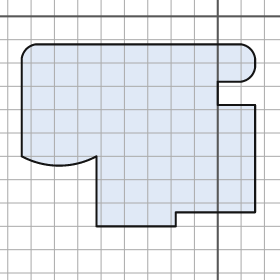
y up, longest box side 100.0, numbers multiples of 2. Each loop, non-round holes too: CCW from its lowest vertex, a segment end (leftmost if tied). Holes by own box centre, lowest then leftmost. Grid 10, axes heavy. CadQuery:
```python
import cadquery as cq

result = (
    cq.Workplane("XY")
    .moveTo(-52.0, -90.0)
    .lineTo(-18.0, -90.0)
    .lineTo(-18.0, -84.0)
    .lineTo(16.0, -84.0)
    .lineTo(16.0, -38.0)
    .lineTo(0.0, -38.0)
    .lineTo(0.0, -28.0)
    .lineTo(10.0, -28.0)
    .threePointArc((14.0, -26.0), (16.0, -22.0))
    .lineTo(16.0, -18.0)
    .threePointArc((14.0, -14.0), (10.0, -12.0))
    .lineTo(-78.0, -12.0)
    .threePointArc((-82.0, -14.0), (-84.0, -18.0))
    .lineTo(-84.0, -60.0)
    .threePointArc((-68.0, -64.0), (-52.0, -60.0))
    .close()
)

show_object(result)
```